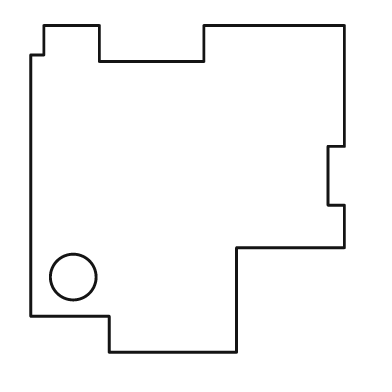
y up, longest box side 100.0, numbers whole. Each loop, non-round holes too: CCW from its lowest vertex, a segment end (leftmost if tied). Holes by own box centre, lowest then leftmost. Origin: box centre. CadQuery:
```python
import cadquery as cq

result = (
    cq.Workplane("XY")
    .moveTo(-24.0, -50.0)
    .lineTo(15.0, -50.0)
    .lineTo(15.0, -18.0)
    .lineTo(48.0, -18.0)
    .lineTo(48.0, -5.0)
    .lineTo(43.0, -5.0)
    .lineTo(43.0, 13.0)
    .lineTo(48.0, 13.0)
    .lineTo(48.0, 50.0)
    .lineTo(5.0, 50.0)
    .lineTo(5.0, 39.0)
    .lineTo(-27.0, 39.0)
    .lineTo(-27.0, 50.0)
    .lineTo(-44.0, 50.0)
    .lineTo(-44.0, 41.0)
    .lineTo(-48.0, 41.0)
    .lineTo(-48.0, -39.0)
    .lineTo(-24.0, -39.0)
    .close()
    .moveTo(-35.0, -27.0)
    .circle(7.0)
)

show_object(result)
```